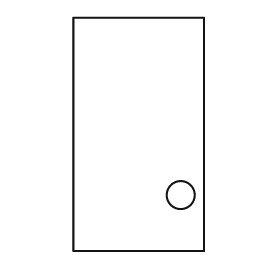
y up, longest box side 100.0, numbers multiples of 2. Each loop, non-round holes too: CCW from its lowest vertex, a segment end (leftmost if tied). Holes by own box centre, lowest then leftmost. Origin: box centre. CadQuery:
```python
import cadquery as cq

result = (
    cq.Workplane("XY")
    .moveTo(-28.0, -50.0)
    .lineTo(28.0, -50.0)
    .lineTo(28.0, 50.0)
    .lineTo(-28.0, 50.0)
    .close()
    .moveTo(18.0, -26.0)
    .circle(6.0)
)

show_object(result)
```